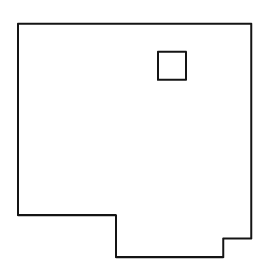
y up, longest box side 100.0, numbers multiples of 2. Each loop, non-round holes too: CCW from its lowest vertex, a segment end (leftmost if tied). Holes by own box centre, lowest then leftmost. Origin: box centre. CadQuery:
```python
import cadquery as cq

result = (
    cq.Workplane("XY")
    .moveTo(-8.0, -50.0)
    .lineTo(38.0, -50.0)
    .lineTo(38.0, -42.0)
    .lineTo(50.0, -42.0)
    .lineTo(50.0, 50.0)
    .lineTo(-50.0, 50.0)
    .lineTo(-50.0, -32.0)
    .lineTo(-8.0, -32.0)
    .close()
    .moveTo(10.0, 26.0)
    .lineTo(22.0, 26.0)
    .lineTo(22.0, 38.0)
    .lineTo(10.0, 38.0)
    .close()
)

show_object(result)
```